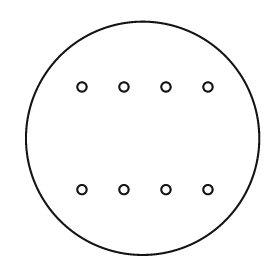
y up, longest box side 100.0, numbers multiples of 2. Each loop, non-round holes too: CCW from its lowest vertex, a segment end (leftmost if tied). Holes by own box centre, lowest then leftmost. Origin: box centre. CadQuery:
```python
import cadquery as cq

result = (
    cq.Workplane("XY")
    .moveTo(0.0, 0.0)
    .circle(50.0)
    .moveTo(-26.0, -22.0)
    .circle(2.0)
    .moveTo(-8.0, -22.0)
    .circle(2.0)
    .moveTo(10.0, -22.0)
    .circle(2.0)
    .moveTo(28.0, -22.0)
    .circle(2.0)
    .moveTo(-26.0, 22.0)
    .circle(2.0)
    .moveTo(-8.0, 22.0)
    .circle(2.0)
    .moveTo(10.0, 22.0)
    .circle(2.0)
    .moveTo(28.0, 22.0)
    .circle(2.0)
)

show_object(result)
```